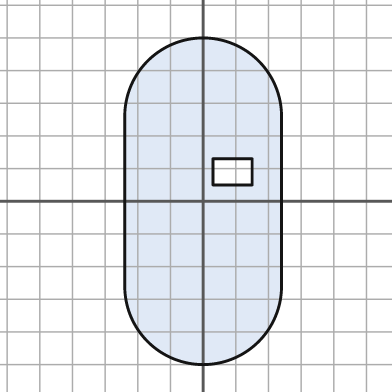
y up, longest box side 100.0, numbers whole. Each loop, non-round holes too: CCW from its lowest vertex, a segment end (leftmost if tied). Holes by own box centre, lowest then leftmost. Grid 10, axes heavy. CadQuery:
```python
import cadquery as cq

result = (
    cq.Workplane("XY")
    .moveTo(-24.0, -26.0)
    .threePointArc((0.0, -50.0), (24.0, -26.0))
    .lineTo(24.0, 26.0)
    .threePointArc((0.0, 50.0), (-24.0, 26.0))
    .close()
    .moveTo(3.0, 5.0)
    .lineTo(15.0, 5.0)
    .lineTo(15.0, 13.0)
    .lineTo(3.0, 13.0)
    .close()
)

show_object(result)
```